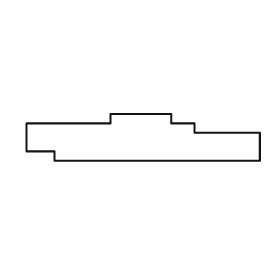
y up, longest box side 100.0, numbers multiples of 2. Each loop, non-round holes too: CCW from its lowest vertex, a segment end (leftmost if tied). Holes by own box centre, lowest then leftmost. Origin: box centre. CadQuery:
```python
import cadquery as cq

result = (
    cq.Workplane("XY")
    .moveTo(-38.0, -10.0)
    .lineTo(50.0, -10.0)
    .lineTo(50.0, 2.0)
    .lineTo(22.0, 2.0)
    .lineTo(22.0, 6.0)
    .lineTo(12.0, 6.0)
    .lineTo(12.0, 10.0)
    .lineTo(-14.0, 10.0)
    .lineTo(-14.0, 6.0)
    .lineTo(-50.0, 6.0)
    .lineTo(-50.0, -6.0)
    .lineTo(-38.0, -6.0)
    .close()
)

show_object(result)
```